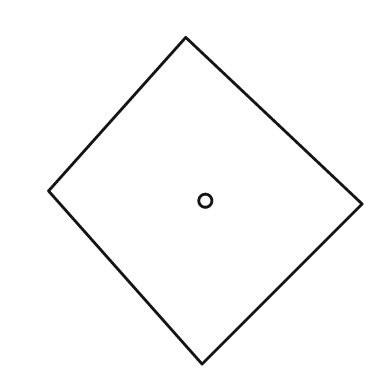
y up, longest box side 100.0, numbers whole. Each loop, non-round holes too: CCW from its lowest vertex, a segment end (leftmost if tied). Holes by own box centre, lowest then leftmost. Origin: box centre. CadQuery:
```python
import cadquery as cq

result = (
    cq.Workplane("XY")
    .moveTo(-1.0, -50.0)
    .lineTo(48.0, -1.0)
    .lineTo(-6.0, 50.0)
    .lineTo(-48.0, 3.0)
    .close()
    .moveTo(0.0, 0.0)
    .circle(2.0)
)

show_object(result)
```